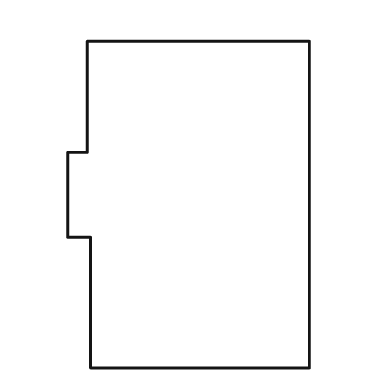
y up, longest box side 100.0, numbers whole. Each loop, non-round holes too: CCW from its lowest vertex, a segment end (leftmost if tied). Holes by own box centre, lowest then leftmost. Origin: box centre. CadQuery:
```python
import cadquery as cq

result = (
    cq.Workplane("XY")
    .moveTo(-30.0, -50.0)
    .lineTo(37.0, -50.0)
    .lineTo(37.0, 50.0)
    .lineTo(-31.0, 50.0)
    .lineTo(-31.0, 16.0)
    .lineTo(-37.0, 16.0)
    .lineTo(-37.0, -10.0)
    .lineTo(-30.0, -10.0)
    .close()
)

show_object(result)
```